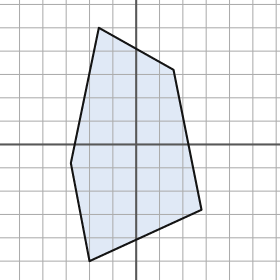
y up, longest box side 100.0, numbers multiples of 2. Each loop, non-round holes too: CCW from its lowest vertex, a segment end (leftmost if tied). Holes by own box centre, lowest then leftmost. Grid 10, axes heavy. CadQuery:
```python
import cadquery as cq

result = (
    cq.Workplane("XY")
    .moveTo(-20.0, -50.0)
    .lineTo(28.0, -28.0)
    .lineTo(16.0, 32.0)
    .lineTo(-16.0, 50.0)
    .lineTo(-28.0, -8.0)
    .close()
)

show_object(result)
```